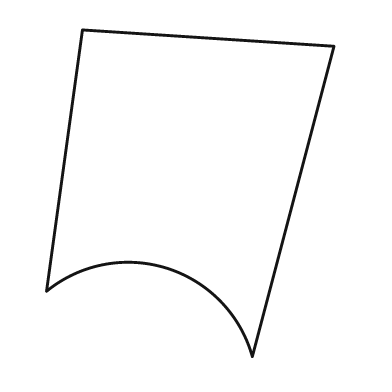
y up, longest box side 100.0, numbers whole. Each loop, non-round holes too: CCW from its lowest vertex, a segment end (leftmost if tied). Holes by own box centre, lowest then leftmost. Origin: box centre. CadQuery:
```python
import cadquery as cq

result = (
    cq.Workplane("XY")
    .moveTo(19.0, -50.0)
    .lineTo(44.0, 45.0)
    .lineTo(-33.0, 50.0)
    .lineTo(-44.0, -30.0)
    .threePointArc((-7.0, -23.0), (19.0, -50.0))
    .close()
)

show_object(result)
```